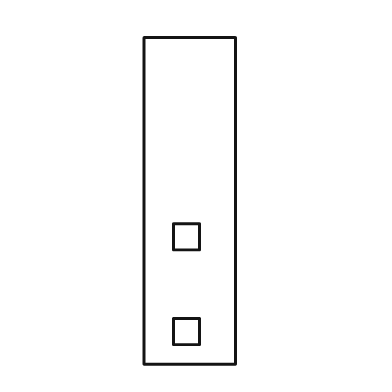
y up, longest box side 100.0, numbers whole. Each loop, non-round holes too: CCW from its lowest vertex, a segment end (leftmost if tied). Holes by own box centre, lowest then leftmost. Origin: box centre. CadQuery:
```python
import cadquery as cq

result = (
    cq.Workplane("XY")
    .moveTo(-14.0, -50.0)
    .lineTo(14.0, -50.0)
    .lineTo(14.0, 50.0)
    .lineTo(-14.0, 50.0)
    .close()
    .moveTo(-5.0, -44.0)
    .lineTo(3.0, -44.0)
    .lineTo(3.0, -36.0)
    .lineTo(-5.0, -36.0)
    .close()
    .moveTo(-5.0, -15.0)
    .lineTo(3.0, -15.0)
    .lineTo(3.0, -7.0)
    .lineTo(-5.0, -7.0)
    .close()
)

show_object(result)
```